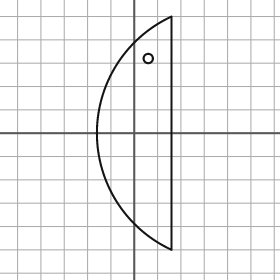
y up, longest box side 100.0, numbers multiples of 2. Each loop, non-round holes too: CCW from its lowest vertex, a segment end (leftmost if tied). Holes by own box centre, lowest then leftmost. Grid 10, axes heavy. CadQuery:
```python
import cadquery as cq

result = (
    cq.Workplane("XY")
    .moveTo(16.0, -50.0)
    .lineTo(16.0, 50.0)
    .threePointArc((-16.0, 0.0), (16.0, -50.0))
    .close()
    .moveTo(6.0, 32.0)
    .circle(2.0)
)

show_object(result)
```